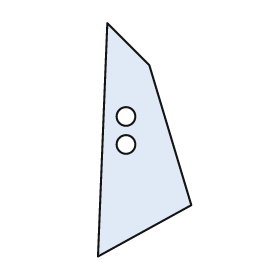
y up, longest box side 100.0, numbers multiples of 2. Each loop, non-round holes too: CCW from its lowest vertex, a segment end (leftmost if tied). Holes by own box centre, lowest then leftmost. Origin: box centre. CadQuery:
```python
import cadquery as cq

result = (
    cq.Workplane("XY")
    .moveTo(-20.0, -50.0)
    .lineTo(20.0, -28.0)
    .lineTo(2.0, 32.0)
    .lineTo(-16.0, 50.0)
    .close()
    .moveTo(-8.0, -2.0)
    .circle(4.0)
    .moveTo(-8.0, 10.0)
    .circle(4.0)
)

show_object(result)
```